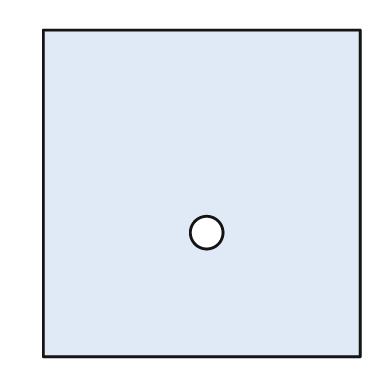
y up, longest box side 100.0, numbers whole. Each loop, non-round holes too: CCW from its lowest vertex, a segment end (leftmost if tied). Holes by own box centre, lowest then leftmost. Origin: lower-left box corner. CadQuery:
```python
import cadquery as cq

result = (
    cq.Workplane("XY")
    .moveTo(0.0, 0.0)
    .lineTo(97.0, 0.0)
    .lineTo(97.0, 100.0)
    .lineTo(0.0, 100.0)
    .close()
    .moveTo(50.0, 38.0)
    .circle(5.0)
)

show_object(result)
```